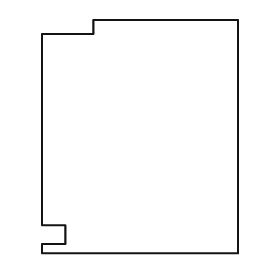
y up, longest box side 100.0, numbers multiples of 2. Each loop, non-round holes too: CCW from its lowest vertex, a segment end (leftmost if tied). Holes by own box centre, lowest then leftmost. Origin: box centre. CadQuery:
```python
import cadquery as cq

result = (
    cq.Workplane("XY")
    .moveTo(-42.0, -50.0)
    .lineTo(42.0, -50.0)
    .lineTo(42.0, 50.0)
    .lineTo(-20.0, 50.0)
    .lineTo(-20.0, 44.0)
    .lineTo(-42.0, 44.0)
    .lineTo(-42.0, -38.0)
    .lineTo(-32.0, -38.0)
    .lineTo(-32.0, -46.0)
    .lineTo(-42.0, -46.0)
    .close()
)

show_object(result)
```